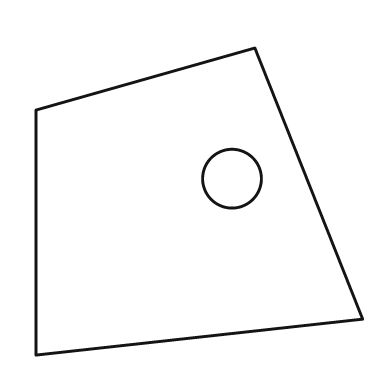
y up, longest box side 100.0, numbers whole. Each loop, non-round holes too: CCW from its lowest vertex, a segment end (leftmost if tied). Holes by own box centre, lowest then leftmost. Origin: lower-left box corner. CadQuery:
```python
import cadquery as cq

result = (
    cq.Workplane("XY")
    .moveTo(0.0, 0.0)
    .lineTo(100.0, 11.0)
    .lineTo(67.0, 94.0)
    .lineTo(0.0, 75.0)
    .close()
    .moveTo(60.0, 54.0)
    .circle(9.0)
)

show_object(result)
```